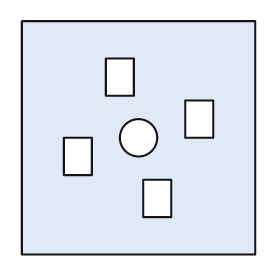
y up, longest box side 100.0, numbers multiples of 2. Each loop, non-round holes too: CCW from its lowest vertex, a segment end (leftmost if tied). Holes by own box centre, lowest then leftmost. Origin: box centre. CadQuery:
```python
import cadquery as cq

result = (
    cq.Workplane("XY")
    .moveTo(-50.0, -50.0)
    .lineTo(50.0, -50.0)
    .lineTo(50.0, 50.0)
    .lineTo(-50.0, 50.0)
    .close()
    .moveTo(2.0, -34.0)
    .lineTo(14.0, -34.0)
    .lineTo(14.0, -18.0)
    .lineTo(2.0, -18.0)
    .close()
    .moveTo(-32.0, -16.0)
    .lineTo(-20.0, -16.0)
    .lineTo(-20.0, 0.0)
    .lineTo(-32.0, 0.0)
    .close()
    .moveTo(0.0, 0.0)
    .circle(8.0)
    .moveTo(20.0, 0.0)
    .lineTo(32.0, 0.0)
    .lineTo(32.0, 16.0)
    .lineTo(20.0, 16.0)
    .close()
    .moveTo(-14.0, 18.0)
    .lineTo(-2.0, 18.0)
    .lineTo(-2.0, 34.0)
    .lineTo(-14.0, 34.0)
    .close()
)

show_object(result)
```